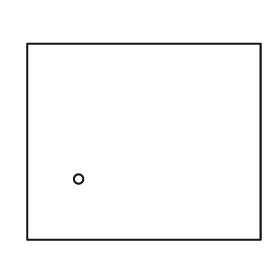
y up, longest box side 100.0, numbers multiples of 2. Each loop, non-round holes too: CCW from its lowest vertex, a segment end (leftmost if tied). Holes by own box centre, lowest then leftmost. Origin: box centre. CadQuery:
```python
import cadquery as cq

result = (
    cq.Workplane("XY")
    .moveTo(-50.0, -42.0)
    .lineTo(50.0, -42.0)
    .lineTo(50.0, 42.0)
    .lineTo(-50.0, 42.0)
    .close()
    .moveTo(-28.0, -16.0)
    .circle(2.0)
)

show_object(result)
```